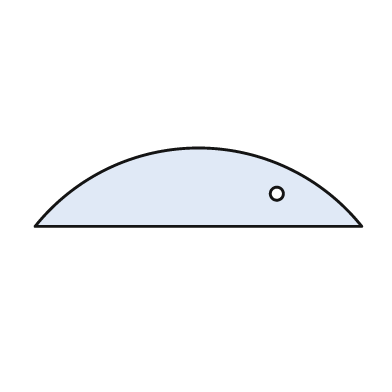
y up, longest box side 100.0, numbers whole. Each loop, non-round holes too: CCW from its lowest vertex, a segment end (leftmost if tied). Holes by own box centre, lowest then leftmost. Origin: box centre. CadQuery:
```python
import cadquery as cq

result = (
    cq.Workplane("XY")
    .moveTo(-50.0, -12.0)
    .lineTo(50.0, -12.0)
    .threePointArc((0.0, 12.0), (-50.0, -12.0))
    .close()
    .moveTo(24.0, -2.0)
    .circle(2.0)
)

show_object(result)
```